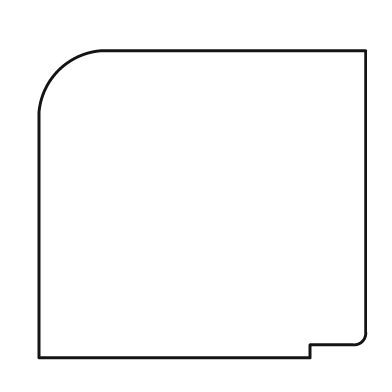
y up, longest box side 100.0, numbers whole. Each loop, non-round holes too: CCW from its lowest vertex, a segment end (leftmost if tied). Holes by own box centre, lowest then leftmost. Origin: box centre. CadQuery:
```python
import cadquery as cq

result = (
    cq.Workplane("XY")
    .moveTo(-50.0, -47.0)
    .lineTo(33.0, -47.0)
    .lineTo(33.0, -43.0)
    .lineTo(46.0, -43.0)
    .threePointArc((49.0, -42.0), (50.0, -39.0))
    .lineTo(50.0, 47.0)
    .lineTo(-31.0, 47.0)
    .threePointArc((-44.0, 41.0), (-50.0, 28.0))
    .close()
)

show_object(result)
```